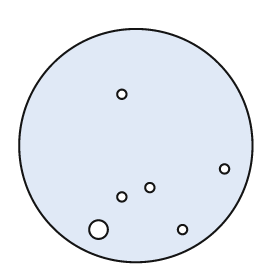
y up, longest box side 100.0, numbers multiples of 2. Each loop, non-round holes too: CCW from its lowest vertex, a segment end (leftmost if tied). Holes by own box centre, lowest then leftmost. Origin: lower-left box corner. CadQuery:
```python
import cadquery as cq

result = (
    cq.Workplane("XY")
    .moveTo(50.0, 50.0)
    .circle(50.0)
    .moveTo(34.0, 14.0)
    .circle(4.0)
    .moveTo(70.0, 14.0)
    .circle(2.0)
    .moveTo(44.0, 28.0)
    .circle(2.0)
    .moveTo(56.0, 32.0)
    .circle(2.0)
    .moveTo(88.0, 40.0)
    .circle(2.0)
    .moveTo(44.0, 72.0)
    .circle(2.0)
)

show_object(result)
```